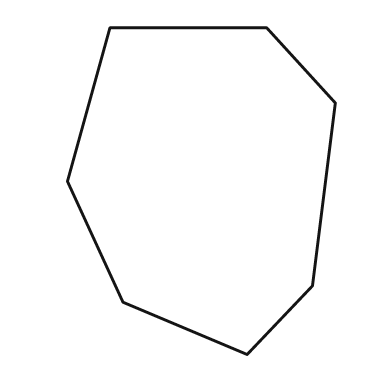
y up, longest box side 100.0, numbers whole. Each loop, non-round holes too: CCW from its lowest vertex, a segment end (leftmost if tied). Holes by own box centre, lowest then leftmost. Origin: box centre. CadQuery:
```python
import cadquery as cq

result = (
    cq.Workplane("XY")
    .moveTo(14.0, -50.0)
    .lineTo(34.0, -29.0)
    .lineTo(41.0, 27.0)
    .lineTo(20.0, 50.0)
    .lineTo(-28.0, 50.0)
    .lineTo(-41.0, 3.0)
    .lineTo(-24.0, -34.0)
    .close()
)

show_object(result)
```